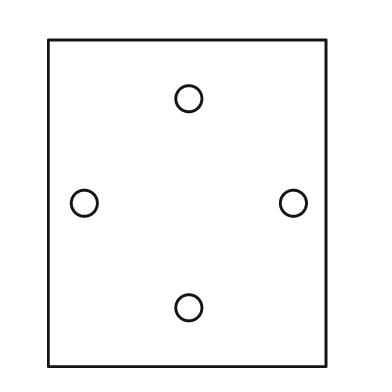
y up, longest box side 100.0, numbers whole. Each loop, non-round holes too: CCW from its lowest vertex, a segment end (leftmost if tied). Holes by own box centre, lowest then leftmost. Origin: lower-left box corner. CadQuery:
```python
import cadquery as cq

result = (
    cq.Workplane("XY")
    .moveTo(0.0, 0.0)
    .lineTo(85.0, 0.0)
    .lineTo(85.0, 100.0)
    .lineTo(0.0, 100.0)
    .close()
    .moveTo(43.0, 18.0)
    .circle(4.0)
    .moveTo(11.0, 50.0)
    .circle(4.0)
    .moveTo(75.0, 50.0)
    .circle(4.0)
    .moveTo(43.0, 82.0)
    .circle(4.0)
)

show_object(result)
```